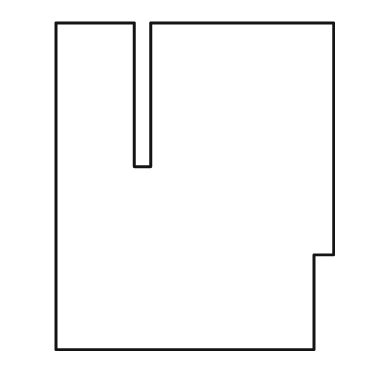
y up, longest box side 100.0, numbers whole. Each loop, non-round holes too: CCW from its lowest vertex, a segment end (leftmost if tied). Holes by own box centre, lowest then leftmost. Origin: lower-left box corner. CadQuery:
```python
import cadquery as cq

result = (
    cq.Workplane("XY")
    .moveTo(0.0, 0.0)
    .lineTo(79.0, 0.0)
    .lineTo(79.0, 29.0)
    .lineTo(85.0, 29.0)
    .lineTo(85.0, 100.0)
    .lineTo(29.0, 100.0)
    .lineTo(29.0, 56.0)
    .lineTo(24.0, 56.0)
    .lineTo(24.0, 100.0)
    .lineTo(0.0, 100.0)
    .close()
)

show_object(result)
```